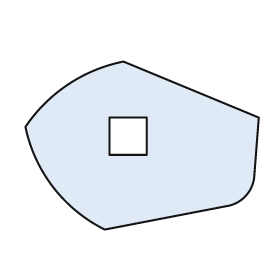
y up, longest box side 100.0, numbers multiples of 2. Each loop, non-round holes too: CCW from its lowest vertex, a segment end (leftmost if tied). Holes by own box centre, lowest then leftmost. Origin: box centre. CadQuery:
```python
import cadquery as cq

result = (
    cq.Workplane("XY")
    .moveTo(-16.0, -36.0)
    .lineTo(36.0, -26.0)
    .threePointArc((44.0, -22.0), (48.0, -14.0))
    .lineTo(50.0, 12.0)
    .lineTo(-8.0, 36.0)
    .threePointArc((-32.0, 26.0), (-50.0, 8.0))
    .threePointArc((-38.0, -18.0), (-16.0, -36.0))
    .close()
    .moveTo(-14.0, -4.0)
    .lineTo(2.0, -4.0)
    .lineTo(2.0, 12.0)
    .lineTo(-14.0, 12.0)
    .close()
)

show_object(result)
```